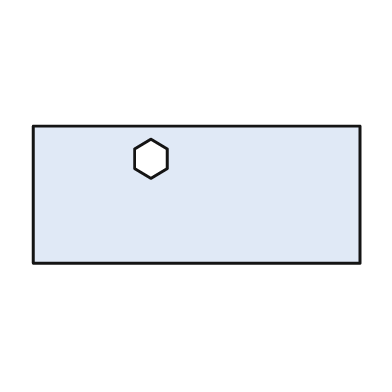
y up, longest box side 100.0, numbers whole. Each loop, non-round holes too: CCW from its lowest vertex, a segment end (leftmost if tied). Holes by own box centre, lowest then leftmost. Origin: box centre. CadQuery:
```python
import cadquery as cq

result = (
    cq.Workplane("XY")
    .moveTo(-50.0, -21.0)
    .lineTo(50.0, -21.0)
    .lineTo(50.0, 21.0)
    .lineTo(-50.0, 21.0)
    .close()
    .moveTo(-14.0, 5.0)
    .lineTo(-9.0, 8.0)
    .lineTo(-9.0, 14.0)
    .lineTo(-14.0, 17.0)
    .lineTo(-19.0, 14.0)
    .lineTo(-19.0, 8.0)
    .close()
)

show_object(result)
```